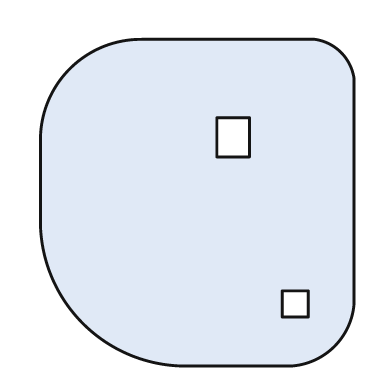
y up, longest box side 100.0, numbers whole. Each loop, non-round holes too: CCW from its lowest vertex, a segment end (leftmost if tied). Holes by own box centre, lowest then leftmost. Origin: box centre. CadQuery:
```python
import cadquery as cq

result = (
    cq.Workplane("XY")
    .moveTo(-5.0, -50.0)
    .lineTo(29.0, -50.0)
    .threePointArc((42.0, -44.0), (48.0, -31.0))
    .lineTo(48.0, 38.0)
    .threePointArc((44.0, 46.0), (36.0, 50.0))
    .lineTo(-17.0, 50.0)
    .threePointArc((-39.0, 41.0), (-48.0, 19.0))
    .lineTo(-48.0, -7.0)
    .threePointArc((-35.0, -37.0), (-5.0, -50.0))
    .close()
    .moveTo(26.0, -35.0)
    .lineTo(34.0, -35.0)
    .lineTo(34.0, -27.0)
    .lineTo(26.0, -27.0)
    .close()
    .moveTo(6.0, 14.0)
    .lineTo(16.0, 14.0)
    .lineTo(16.0, 26.0)
    .lineTo(6.0, 26.0)
    .close()
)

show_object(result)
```